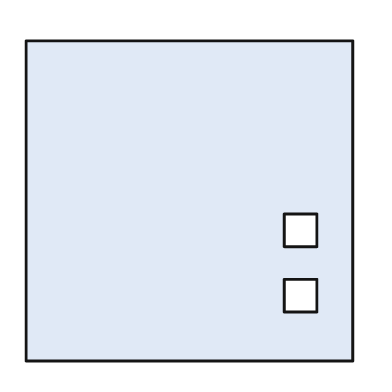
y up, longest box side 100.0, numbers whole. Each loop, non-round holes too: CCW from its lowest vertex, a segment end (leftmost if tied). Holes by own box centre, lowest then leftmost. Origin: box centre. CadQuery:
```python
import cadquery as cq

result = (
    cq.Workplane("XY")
    .moveTo(-50.0, -49.0)
    .lineTo(50.0, -49.0)
    .lineTo(50.0, 49.0)
    .lineTo(-50.0, 49.0)
    .close()
    .moveTo(29.0, -34.0)
    .lineTo(39.0, -34.0)
    .lineTo(39.0, -24.0)
    .lineTo(29.0, -24.0)
    .close()
    .moveTo(29.0, -14.0)
    .lineTo(39.0, -14.0)
    .lineTo(39.0, -4.0)
    .lineTo(29.0, -4.0)
    .close()
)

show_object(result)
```